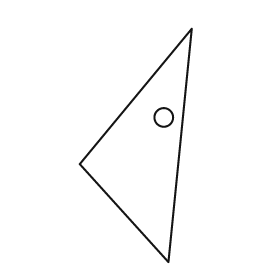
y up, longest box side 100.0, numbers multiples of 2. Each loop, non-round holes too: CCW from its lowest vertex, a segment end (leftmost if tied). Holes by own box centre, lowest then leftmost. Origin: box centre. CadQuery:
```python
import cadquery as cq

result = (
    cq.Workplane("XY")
    .moveTo(14.0, -50.0)
    .lineTo(24.0, 50.0)
    .lineTo(-24.0, -8.0)
    .close()
    .moveTo(12.0, 12.0)
    .circle(4.0)
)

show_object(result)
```